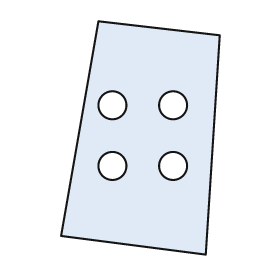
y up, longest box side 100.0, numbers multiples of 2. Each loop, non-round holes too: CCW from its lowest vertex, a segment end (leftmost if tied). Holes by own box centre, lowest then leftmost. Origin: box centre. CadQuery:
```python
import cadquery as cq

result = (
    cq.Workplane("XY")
    .moveTo(28.0, -50.0)
    .lineTo(34.0, 44.0)
    .lineTo(-18.0, 50.0)
    .lineTo(-34.0, -42.0)
    .close()
    .moveTo(-12.0, -12.0)
    .circle(6.0)
    .moveTo(14.0, -12.0)
    .circle(6.0)
    .moveTo(-12.0, 14.0)
    .circle(6.0)
    .moveTo(14.0, 14.0)
    .circle(6.0)
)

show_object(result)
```